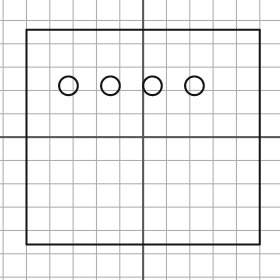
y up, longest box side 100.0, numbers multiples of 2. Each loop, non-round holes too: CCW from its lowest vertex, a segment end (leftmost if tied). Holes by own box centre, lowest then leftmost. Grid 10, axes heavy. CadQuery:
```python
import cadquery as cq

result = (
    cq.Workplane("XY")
    .moveTo(-50.0, -46.0)
    .lineTo(50.0, -46.0)
    .lineTo(50.0, 46.0)
    .lineTo(-50.0, 46.0)
    .close()
    .moveTo(-32.0, 22.0)
    .circle(4.0)
    .moveTo(-14.0, 22.0)
    .circle(4.0)
    .moveTo(4.0, 22.0)
    .circle(4.0)
    .moveTo(22.0, 22.0)
    .circle(4.0)
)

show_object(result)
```